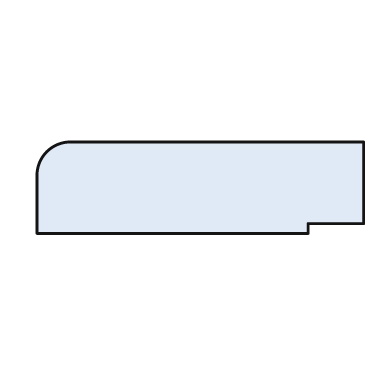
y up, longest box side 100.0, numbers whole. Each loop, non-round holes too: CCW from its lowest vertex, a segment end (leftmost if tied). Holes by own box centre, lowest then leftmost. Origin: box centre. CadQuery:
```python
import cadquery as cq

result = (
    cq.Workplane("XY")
    .moveTo(-50.0, -14.0)
    .lineTo(33.0, -14.0)
    .lineTo(33.0, -11.0)
    .lineTo(50.0, -11.0)
    .lineTo(50.0, 14.0)
    .lineTo(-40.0, 14.0)
    .threePointArc((-47.0, 11.0), (-50.0, 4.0))
    .close()
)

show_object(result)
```